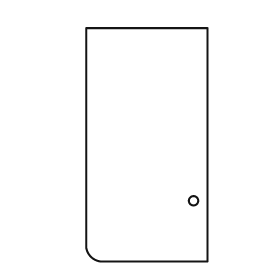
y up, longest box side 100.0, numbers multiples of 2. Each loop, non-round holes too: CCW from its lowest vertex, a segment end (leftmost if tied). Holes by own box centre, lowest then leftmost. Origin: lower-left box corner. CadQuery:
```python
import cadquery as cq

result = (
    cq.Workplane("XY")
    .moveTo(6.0, 0.0)
    .lineTo(52.0, 0.0)
    .lineTo(52.0, 100.0)
    .lineTo(0.0, 100.0)
    .lineTo(0.0, 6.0)
    .threePointArc((2.0, 2.0), (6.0, 0.0))
    .close()
    .moveTo(46.0, 26.0)
    .circle(2.0)
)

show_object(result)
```